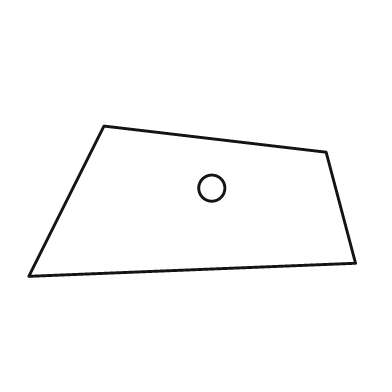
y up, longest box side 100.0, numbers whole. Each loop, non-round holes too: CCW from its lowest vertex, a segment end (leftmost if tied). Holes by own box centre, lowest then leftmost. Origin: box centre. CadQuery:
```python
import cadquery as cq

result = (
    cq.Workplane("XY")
    .moveTo(-50.0, -23.0)
    .lineTo(50.0, -19.0)
    .lineTo(41.0, 15.0)
    .lineTo(-27.0, 23.0)
    .close()
    .moveTo(6.0, 4.0)
    .circle(4.0)
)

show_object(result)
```